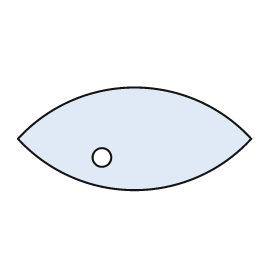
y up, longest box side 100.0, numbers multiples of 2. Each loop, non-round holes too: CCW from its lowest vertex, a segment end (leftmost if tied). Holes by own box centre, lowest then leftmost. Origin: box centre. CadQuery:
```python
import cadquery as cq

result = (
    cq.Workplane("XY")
    .moveTo(-50.0, 0.0)
    .threePointArc((0.0, -22.0), (50.0, 0.0))
    .threePointArc((0.0, 22.0), (-50.0, 0.0))
    .close()
    .moveTo(-14.0, -8.0)
    .circle(4.0)
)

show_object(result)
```